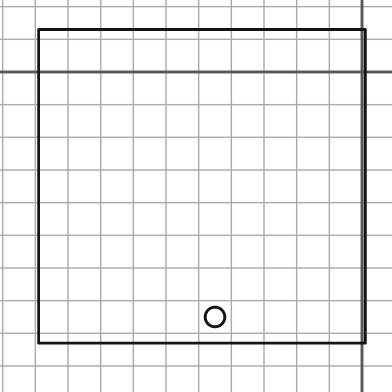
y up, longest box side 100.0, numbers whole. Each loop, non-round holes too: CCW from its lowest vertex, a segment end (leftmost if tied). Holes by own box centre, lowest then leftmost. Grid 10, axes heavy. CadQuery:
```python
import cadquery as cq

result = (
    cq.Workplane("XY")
    .moveTo(-99.0, -83.0)
    .lineTo(1.0, -83.0)
    .lineTo(1.0, 13.0)
    .lineTo(-99.0, 13.0)
    .close()
    .moveTo(-45.0, -75.0)
    .circle(3.0)
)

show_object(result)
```